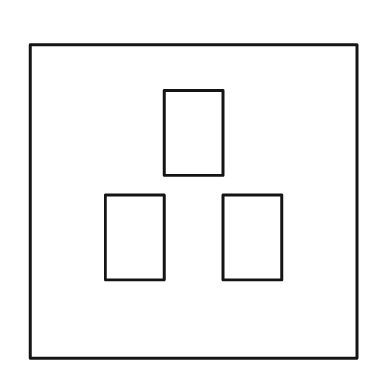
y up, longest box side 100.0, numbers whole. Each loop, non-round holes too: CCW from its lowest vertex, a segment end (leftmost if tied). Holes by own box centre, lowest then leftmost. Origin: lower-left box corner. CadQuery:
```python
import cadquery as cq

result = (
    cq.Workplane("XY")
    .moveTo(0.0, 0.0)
    .lineTo(100.0, 0.0)
    .lineTo(100.0, 96.0)
    .lineTo(0.0, 96.0)
    .close()
    .moveTo(23.0, 24.0)
    .lineTo(41.0, 24.0)
    .lineTo(41.0, 50.0)
    .lineTo(23.0, 50.0)
    .close()
    .moveTo(59.0, 24.0)
    .lineTo(77.0, 24.0)
    .lineTo(77.0, 50.0)
    .lineTo(59.0, 50.0)
    .close()
    .moveTo(41.0, 56.0)
    .lineTo(59.0, 56.0)
    .lineTo(59.0, 82.0)
    .lineTo(41.0, 82.0)
    .close()
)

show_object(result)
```